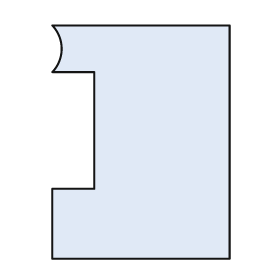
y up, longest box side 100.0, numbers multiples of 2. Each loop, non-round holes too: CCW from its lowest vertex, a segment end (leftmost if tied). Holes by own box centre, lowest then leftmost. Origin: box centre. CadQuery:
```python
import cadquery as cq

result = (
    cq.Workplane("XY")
    .moveTo(-38.0, -50.0)
    .lineTo(38.0, -50.0)
    .lineTo(38.0, 50.0)
    .lineTo(-38.0, 50.0)
    .threePointArc((-34.0, 40.0), (-38.0, 30.0))
    .lineTo(-20.0, 30.0)
    .lineTo(-20.0, -20.0)
    .lineTo(-38.0, -20.0)
    .close()
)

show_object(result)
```